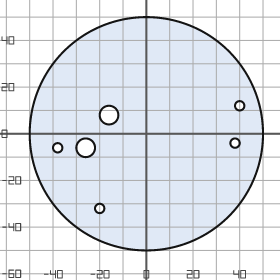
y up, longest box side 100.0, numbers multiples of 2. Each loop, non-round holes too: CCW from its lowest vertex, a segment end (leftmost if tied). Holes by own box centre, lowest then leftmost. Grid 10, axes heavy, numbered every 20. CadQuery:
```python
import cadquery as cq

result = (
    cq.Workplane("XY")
    .moveTo(0.0, 0.0)
    .circle(50.0)
    .moveTo(-20.0, -32.0)
    .circle(2.0)
    .moveTo(-38.0, -6.0)
    .circle(2.0)
    .moveTo(-26.0, -6.0)
    .circle(4.0)
    .moveTo(38.0, -4.0)
    .circle(2.0)
    .moveTo(-16.0, 8.0)
    .circle(4.0)
    .moveTo(40.0, 12.0)
    .circle(2.0)
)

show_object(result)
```